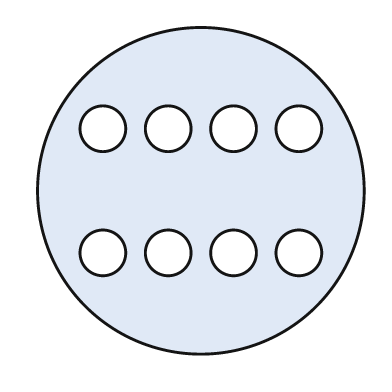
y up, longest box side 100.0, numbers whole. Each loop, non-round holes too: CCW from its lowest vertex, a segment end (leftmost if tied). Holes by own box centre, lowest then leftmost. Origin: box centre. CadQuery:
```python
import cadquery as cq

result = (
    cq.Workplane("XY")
    .moveTo(0.0, 0.0)
    .circle(50.0)
    .moveTo(-30.0, -19.0)
    .circle(7.0)
    .moveTo(-10.0, -19.0)
    .circle(7.0)
    .moveTo(10.0, -19.0)
    .circle(7.0)
    .moveTo(30.0, -19.0)
    .circle(7.0)
    .moveTo(-30.0, 19.0)
    .circle(7.0)
    .moveTo(-10.0, 19.0)
    .circle(7.0)
    .moveTo(10.0, 19.0)
    .circle(7.0)
    .moveTo(30.0, 19.0)
    .circle(7.0)
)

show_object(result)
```